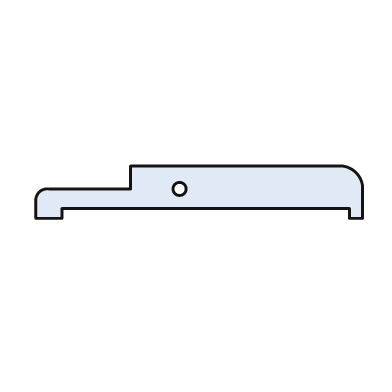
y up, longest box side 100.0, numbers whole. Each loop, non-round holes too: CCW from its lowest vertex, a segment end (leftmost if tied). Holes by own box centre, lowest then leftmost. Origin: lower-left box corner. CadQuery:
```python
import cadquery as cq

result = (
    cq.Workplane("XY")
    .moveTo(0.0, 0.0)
    .lineTo(8.0, 0.0)
    .lineTo(8.0, 3.0)
    .lineTo(96.0, 3.0)
    .lineTo(96.0, 0.0)
    .lineTo(100.0, 0.0)
    .lineTo(100.0, 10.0)
    .threePointArc((98.0, 14.0), (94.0, 16.0))
    .lineTo(29.0, 16.0)
    .lineTo(29.0, 9.0)
    .lineTo(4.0, 9.0)
    .threePointArc((1.0, 8.0), (0.0, 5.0))
    .close()
    .moveTo(44.0, 9.0)
    .circle(2.0)
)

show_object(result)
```